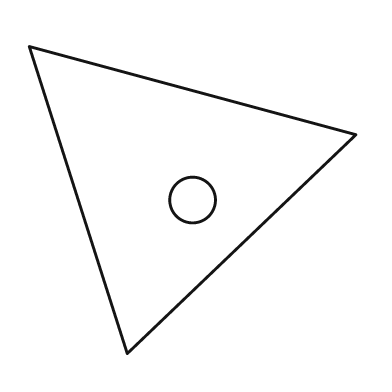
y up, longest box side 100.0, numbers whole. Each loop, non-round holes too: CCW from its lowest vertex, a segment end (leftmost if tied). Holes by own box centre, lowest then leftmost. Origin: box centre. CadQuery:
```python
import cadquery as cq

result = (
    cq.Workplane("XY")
    .moveTo(-20.0, -47.0)
    .lineTo(50.0, 20.0)
    .lineTo(-50.0, 47.0)
    .close()
    .moveTo(0.0, 0.0)
    .circle(7.0)
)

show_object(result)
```